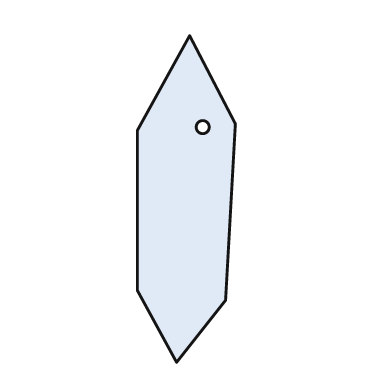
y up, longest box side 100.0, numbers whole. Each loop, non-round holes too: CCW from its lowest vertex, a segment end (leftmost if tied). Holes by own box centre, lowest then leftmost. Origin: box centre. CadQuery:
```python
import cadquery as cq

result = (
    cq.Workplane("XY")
    .moveTo(-3.0, -50.0)
    .lineTo(12.0, -31.0)
    .lineTo(15.0, 23.0)
    .lineTo(1.0, 50.0)
    .lineTo(-15.0, 21.0)
    .lineTo(-15.0, -28.0)
    .close()
    .moveTo(5.0, 22.0)
    .circle(2.0)
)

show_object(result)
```